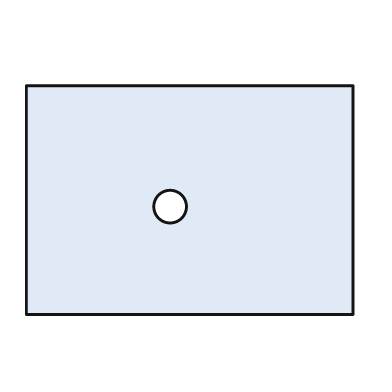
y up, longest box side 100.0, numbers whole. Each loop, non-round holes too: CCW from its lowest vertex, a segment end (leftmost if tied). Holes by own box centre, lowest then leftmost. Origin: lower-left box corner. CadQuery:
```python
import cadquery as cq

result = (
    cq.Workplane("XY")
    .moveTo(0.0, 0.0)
    .lineTo(100.0, 0.0)
    .lineTo(100.0, 70.0)
    .lineTo(0.0, 70.0)
    .close()
    .moveTo(44.0, 33.0)
    .circle(5.0)
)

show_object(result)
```